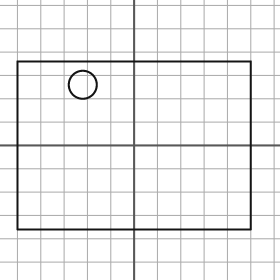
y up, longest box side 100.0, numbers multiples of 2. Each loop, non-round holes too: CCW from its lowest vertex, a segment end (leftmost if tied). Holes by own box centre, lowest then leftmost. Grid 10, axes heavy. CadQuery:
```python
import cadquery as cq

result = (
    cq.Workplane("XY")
    .moveTo(-50.0, -36.0)
    .lineTo(50.0, -36.0)
    .lineTo(50.0, 36.0)
    .lineTo(-50.0, 36.0)
    .close()
    .moveTo(-22.0, 26.0)
    .circle(6.0)
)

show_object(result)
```